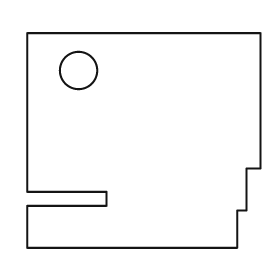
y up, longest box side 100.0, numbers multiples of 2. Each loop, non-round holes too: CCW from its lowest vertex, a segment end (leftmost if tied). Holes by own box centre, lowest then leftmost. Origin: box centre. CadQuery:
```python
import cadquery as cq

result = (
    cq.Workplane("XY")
    .moveTo(-50.0, -46.0)
    .lineTo(40.0, -46.0)
    .lineTo(40.0, -30.0)
    .lineTo(44.0, -30.0)
    .lineTo(44.0, -12.0)
    .lineTo(50.0, -12.0)
    .lineTo(50.0, 46.0)
    .lineTo(-50.0, 46.0)
    .lineTo(-50.0, -22.0)
    .lineTo(-16.0, -22.0)
    .lineTo(-16.0, -28.0)
    .lineTo(-50.0, -28.0)
    .close()
    .moveTo(-28.0, 30.0)
    .circle(8.0)
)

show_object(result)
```